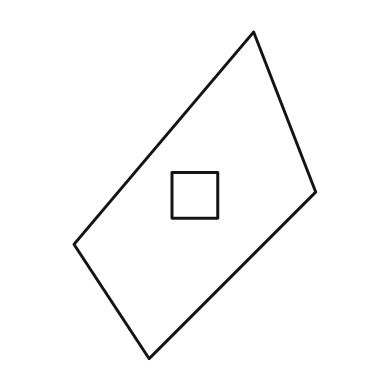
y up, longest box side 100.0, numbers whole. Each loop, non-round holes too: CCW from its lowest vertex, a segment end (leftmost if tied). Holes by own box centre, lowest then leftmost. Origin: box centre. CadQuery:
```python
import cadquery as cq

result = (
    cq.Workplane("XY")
    .moveTo(-14.0, -50.0)
    .lineTo(37.0, 1.0)
    .lineTo(18.0, 50.0)
    .lineTo(-37.0, -15.0)
    .close()
    .moveTo(-7.0, -7.0)
    .lineTo(7.0, -7.0)
    .lineTo(7.0, 7.0)
    .lineTo(-7.0, 7.0)
    .close()
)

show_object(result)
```